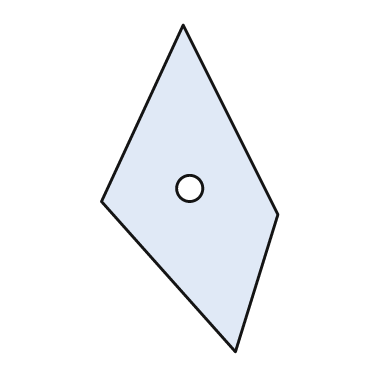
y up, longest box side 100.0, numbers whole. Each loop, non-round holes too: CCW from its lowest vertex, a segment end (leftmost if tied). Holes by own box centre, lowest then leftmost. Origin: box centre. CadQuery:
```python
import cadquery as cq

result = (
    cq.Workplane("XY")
    .moveTo(14.0, -50.0)
    .lineTo(27.0, -8.0)
    .lineTo(-2.0, 50.0)
    .lineTo(-27.0, -4.0)
    .close()
    .moveTo(0.0, 0.0)
    .circle(4.0)
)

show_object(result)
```